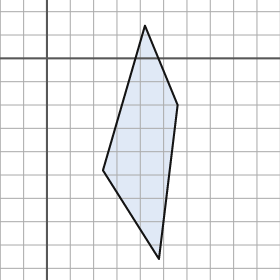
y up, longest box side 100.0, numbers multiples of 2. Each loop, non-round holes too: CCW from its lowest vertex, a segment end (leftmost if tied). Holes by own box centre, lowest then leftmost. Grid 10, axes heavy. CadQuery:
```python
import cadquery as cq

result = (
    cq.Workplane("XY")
    .moveTo(48.0, -86.0)
    .lineTo(56.0, -20.0)
    .lineTo(42.0, 14.0)
    .lineTo(24.0, -48.0)
    .close()
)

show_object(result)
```